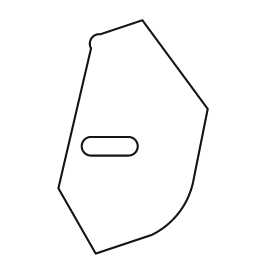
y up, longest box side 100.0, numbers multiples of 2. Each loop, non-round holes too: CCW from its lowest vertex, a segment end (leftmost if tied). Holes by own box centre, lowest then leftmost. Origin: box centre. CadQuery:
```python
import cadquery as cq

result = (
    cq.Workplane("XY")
    .moveTo(-16.0, -50.0)
    .lineTo(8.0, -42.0)
    .threePointArc((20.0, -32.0), (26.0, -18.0))
    .lineTo(32.0, 12.0)
    .lineTo(4.0, 50.0)
    .lineTo(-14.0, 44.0)
    .threePointArc((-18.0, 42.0), (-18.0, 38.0))
    .lineTo(-32.0, -22.0)
    .close()
    .moveTo(-18.0, -8.0)
    .lineTo(-2.0, -8.0)
    .threePointArc((2.0, -4.0), (-2.0, 0.0))
    .lineTo(-18.0, 0.0)
    .threePointArc((-22.0, -4.0), (-18.0, -8.0))
    .close()
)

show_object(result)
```